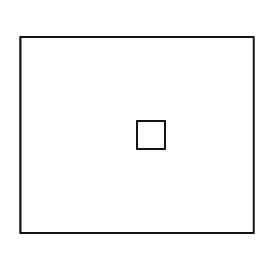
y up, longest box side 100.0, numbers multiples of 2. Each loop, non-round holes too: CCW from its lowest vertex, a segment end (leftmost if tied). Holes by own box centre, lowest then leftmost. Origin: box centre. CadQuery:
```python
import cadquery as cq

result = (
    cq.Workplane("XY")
    .moveTo(-50.0, -42.0)
    .lineTo(50.0, -42.0)
    .lineTo(50.0, 42.0)
    .lineTo(-50.0, 42.0)
    .close()
    .moveTo(0.0, -6.0)
    .lineTo(12.0, -6.0)
    .lineTo(12.0, 6.0)
    .lineTo(0.0, 6.0)
    .close()
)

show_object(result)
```